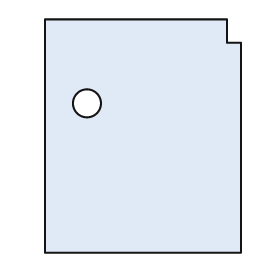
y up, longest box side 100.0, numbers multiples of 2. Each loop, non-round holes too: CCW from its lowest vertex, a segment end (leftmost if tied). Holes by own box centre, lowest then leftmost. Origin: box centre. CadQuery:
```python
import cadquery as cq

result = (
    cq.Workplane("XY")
    .moveTo(-42.0, -50.0)
    .lineTo(42.0, -50.0)
    .lineTo(42.0, 40.0)
    .lineTo(36.0, 40.0)
    .lineTo(36.0, 50.0)
    .lineTo(-42.0, 50.0)
    .close()
    .moveTo(-24.0, 14.0)
    .circle(6.0)
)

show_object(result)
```